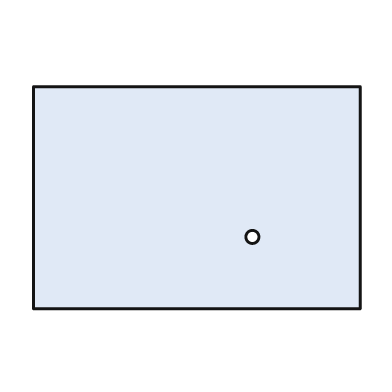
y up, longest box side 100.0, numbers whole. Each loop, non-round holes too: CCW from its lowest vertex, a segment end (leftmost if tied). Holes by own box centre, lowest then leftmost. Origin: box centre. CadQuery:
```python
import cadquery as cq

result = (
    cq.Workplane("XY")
    .moveTo(-50.0, -34.0)
    .lineTo(50.0, -34.0)
    .lineTo(50.0, 34.0)
    .lineTo(-50.0, 34.0)
    .close()
    .moveTo(17.0, -12.0)
    .circle(2.0)
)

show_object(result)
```